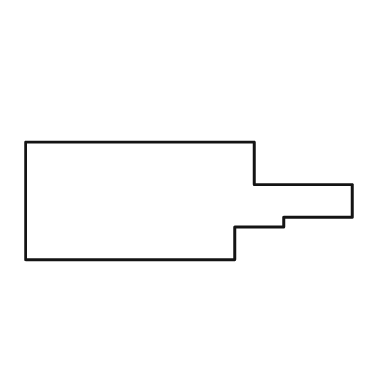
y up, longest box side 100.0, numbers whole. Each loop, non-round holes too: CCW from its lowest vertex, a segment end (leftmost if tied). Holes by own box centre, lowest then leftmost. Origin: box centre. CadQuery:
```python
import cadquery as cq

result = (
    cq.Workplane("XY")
    .moveTo(-50.0, -18.0)
    .lineTo(14.0, -18.0)
    .lineTo(14.0, -8.0)
    .lineTo(29.0, -8.0)
    .lineTo(29.0, -5.0)
    .lineTo(50.0, -5.0)
    .lineTo(50.0, 5.0)
    .lineTo(20.0, 5.0)
    .lineTo(20.0, 18.0)
    .lineTo(-50.0, 18.0)
    .close()
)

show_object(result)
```